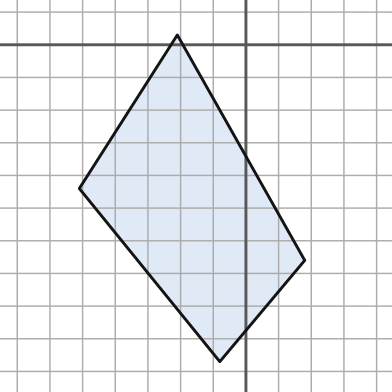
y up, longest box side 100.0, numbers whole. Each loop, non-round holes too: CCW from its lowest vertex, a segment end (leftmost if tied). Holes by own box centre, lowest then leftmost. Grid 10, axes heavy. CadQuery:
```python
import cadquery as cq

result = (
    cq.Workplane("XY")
    .moveTo(-8.0, -97.0)
    .lineTo(18.0, -66.0)
    .lineTo(-21.0, 3.0)
    .lineTo(-51.0, -44.0)
    .close()
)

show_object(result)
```